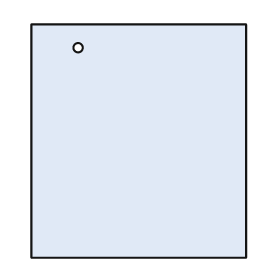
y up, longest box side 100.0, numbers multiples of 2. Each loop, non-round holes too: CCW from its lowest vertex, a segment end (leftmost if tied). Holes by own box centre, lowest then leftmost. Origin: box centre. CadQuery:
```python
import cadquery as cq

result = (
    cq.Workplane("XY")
    .moveTo(-46.0, -50.0)
    .lineTo(46.0, -50.0)
    .lineTo(46.0, 50.0)
    .lineTo(-46.0, 50.0)
    .close()
    .moveTo(-26.0, 40.0)
    .circle(2.0)
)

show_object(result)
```